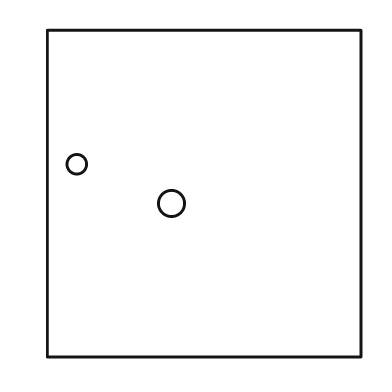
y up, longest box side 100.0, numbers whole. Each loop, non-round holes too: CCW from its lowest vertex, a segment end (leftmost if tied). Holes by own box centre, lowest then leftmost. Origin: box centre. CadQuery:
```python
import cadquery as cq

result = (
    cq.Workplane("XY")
    .moveTo(-48.0, -50.0)
    .lineTo(48.0, -50.0)
    .lineTo(48.0, 50.0)
    .lineTo(-48.0, 50.0)
    .close()
    .moveTo(-10.0, -3.0)
    .circle(4.0)
    .moveTo(-39.0, 9.0)
    .circle(3.0)
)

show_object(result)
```